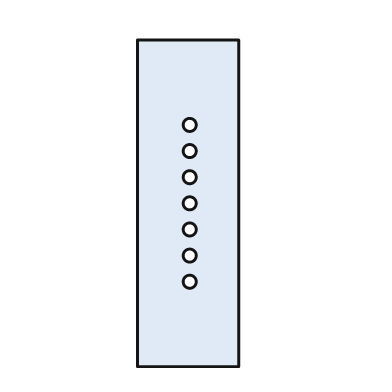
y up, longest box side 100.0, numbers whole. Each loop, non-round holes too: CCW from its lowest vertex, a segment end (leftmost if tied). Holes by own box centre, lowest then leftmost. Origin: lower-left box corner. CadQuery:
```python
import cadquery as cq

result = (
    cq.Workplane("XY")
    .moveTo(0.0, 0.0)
    .lineTo(31.0, 0.0)
    .lineTo(31.0, 100.0)
    .lineTo(0.0, 100.0)
    .close()
    .moveTo(16.0, 26.0)
    .circle(2.0)
    .moveTo(16.0, 34.0)
    .circle(2.0)
    .moveTo(16.0, 42.0)
    .circle(2.0)
    .moveTo(16.0, 50.0)
    .circle(2.0)
    .moveTo(16.0, 58.0)
    .circle(2.0)
    .moveTo(16.0, 66.0)
    .circle(2.0)
    .moveTo(16.0, 74.0)
    .circle(2.0)
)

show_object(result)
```